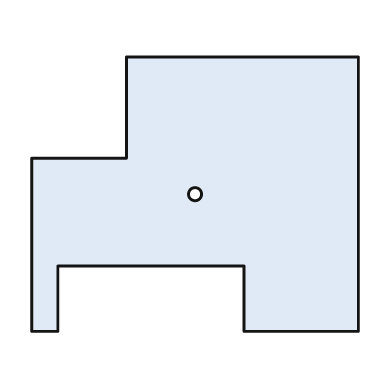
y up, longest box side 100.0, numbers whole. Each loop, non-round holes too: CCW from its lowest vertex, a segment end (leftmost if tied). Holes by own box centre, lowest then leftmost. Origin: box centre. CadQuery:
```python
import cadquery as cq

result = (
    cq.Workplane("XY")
    .moveTo(-50.0, -42.0)
    .lineTo(-42.0, -42.0)
    .lineTo(-42.0, -22.0)
    .lineTo(15.0, -22.0)
    .lineTo(15.0, -42.0)
    .lineTo(50.0, -42.0)
    .lineTo(50.0, 42.0)
    .lineTo(-21.0, 42.0)
    .lineTo(-21.0, 11.0)
    .lineTo(-50.0, 11.0)
    .close()
    .moveTo(0.0, 0.0)
    .circle(2.0)
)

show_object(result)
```